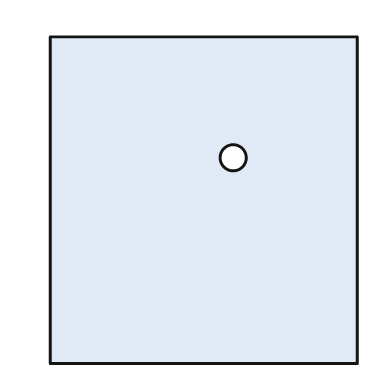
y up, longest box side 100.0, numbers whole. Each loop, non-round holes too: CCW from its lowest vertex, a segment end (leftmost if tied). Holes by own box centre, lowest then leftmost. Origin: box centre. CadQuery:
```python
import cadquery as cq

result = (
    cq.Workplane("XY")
    .moveTo(-47.0, -50.0)
    .lineTo(47.0, -50.0)
    .lineTo(47.0, 50.0)
    .lineTo(-47.0, 50.0)
    .close()
    .moveTo(9.0, 13.0)
    .circle(4.0)
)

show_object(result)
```